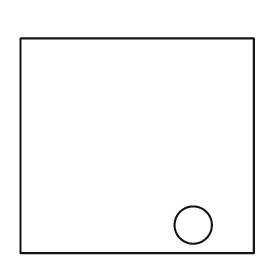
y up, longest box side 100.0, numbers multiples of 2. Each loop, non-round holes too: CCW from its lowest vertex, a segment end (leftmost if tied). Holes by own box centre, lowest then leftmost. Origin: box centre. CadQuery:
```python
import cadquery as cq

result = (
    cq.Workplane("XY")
    .moveTo(-50.0, -46.0)
    .lineTo(50.0, -46.0)
    .lineTo(50.0, 46.0)
    .lineTo(-50.0, 46.0)
    .close()
    .moveTo(24.0, -34.0)
    .circle(8.0)
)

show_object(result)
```